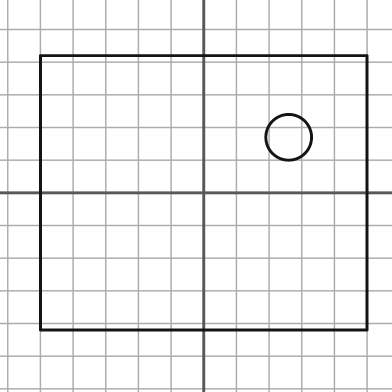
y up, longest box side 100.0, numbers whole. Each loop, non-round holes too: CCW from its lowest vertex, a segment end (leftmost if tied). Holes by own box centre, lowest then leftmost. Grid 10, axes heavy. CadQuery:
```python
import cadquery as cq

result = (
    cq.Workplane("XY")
    .moveTo(-50.0, -42.0)
    .lineTo(50.0, -42.0)
    .lineTo(50.0, 42.0)
    .lineTo(-50.0, 42.0)
    .close()
    .moveTo(26.0, 17.0)
    .circle(7.0)
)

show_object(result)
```